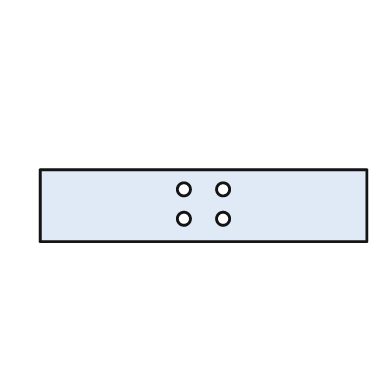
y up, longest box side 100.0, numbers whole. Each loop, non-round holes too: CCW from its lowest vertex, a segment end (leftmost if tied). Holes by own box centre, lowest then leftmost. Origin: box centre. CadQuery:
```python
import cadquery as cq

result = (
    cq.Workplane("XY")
    .moveTo(-50.0, -11.0)
    .lineTo(50.0, -11.0)
    .lineTo(50.0, 11.0)
    .lineTo(-50.0, 11.0)
    .close()
    .moveTo(-6.0, -4.0)
    .circle(2.0)
    .moveTo(6.0, -4.0)
    .circle(2.0)
    .moveTo(-6.0, 5.0)
    .circle(2.0)
    .moveTo(6.0, 5.0)
    .circle(2.0)
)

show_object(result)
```